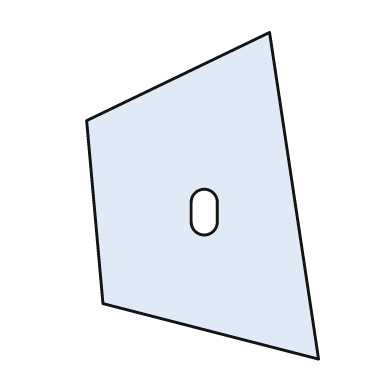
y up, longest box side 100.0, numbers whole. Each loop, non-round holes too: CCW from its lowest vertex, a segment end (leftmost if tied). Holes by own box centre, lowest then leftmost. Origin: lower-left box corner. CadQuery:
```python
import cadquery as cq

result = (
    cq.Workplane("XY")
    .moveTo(71.0, 0.0)
    .lineTo(56.0, 100.0)
    .lineTo(0.0, 73.0)
    .lineTo(5.0, 17.0)
    .close()
    .moveTo(32.0, 42.0)
    .threePointArc((36.0, 38.0), (40.0, 42.0))
    .lineTo(40.0, 48.0)
    .threePointArc((36.0, 52.0), (32.0, 48.0))
    .close()
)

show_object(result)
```